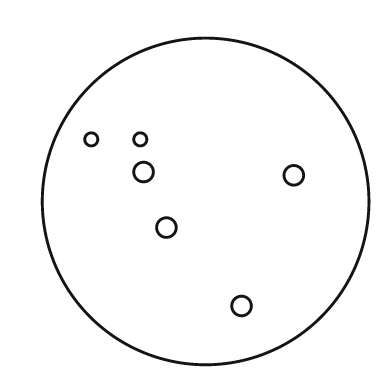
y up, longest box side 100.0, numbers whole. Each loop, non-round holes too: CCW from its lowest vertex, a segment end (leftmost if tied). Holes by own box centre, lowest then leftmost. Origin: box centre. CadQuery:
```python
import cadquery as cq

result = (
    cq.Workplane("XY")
    .moveTo(0.0, 0.0)
    .circle(50.0)
    .moveTo(11.0, -32.0)
    .circle(3.0)
    .moveTo(-12.0, -8.0)
    .circle(3.0)
    .moveTo(27.0, 8.0)
    .circle(3.0)
    .moveTo(-19.0, 9.0)
    .circle(3.0)
    .moveTo(-35.0, 19.0)
    .circle(2.0)
    .moveTo(-20.0, 19.0)
    .circle(2.0)
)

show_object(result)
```